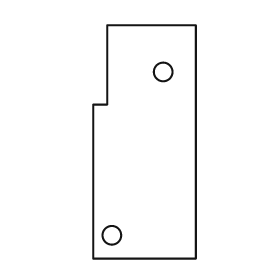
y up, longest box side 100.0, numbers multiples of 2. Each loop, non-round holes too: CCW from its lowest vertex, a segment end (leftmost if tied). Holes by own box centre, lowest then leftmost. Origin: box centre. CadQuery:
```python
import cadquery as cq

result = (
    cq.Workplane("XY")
    .moveTo(-22.0, -50.0)
    .lineTo(22.0, -50.0)
    .lineTo(22.0, 50.0)
    .lineTo(-16.0, 50.0)
    .lineTo(-16.0, 16.0)
    .lineTo(-22.0, 16.0)
    .close()
    .moveTo(-14.0, -40.0)
    .circle(4.0)
    .moveTo(8.0, 30.0)
    .circle(4.0)
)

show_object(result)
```